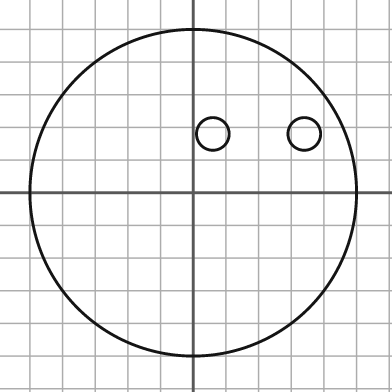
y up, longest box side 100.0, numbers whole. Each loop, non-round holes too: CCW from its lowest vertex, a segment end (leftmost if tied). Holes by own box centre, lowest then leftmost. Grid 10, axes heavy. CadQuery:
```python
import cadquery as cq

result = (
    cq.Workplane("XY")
    .moveTo(0.0, 0.0)
    .circle(50.0)
    .moveTo(6.0, 18.0)
    .circle(5.0)
    .moveTo(34.0, 18.0)
    .circle(5.0)
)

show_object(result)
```